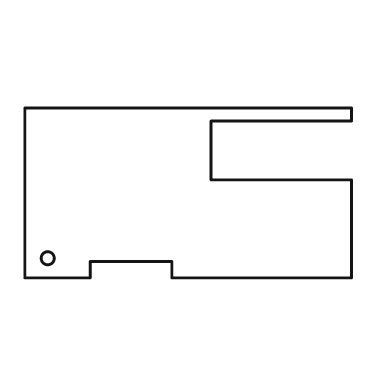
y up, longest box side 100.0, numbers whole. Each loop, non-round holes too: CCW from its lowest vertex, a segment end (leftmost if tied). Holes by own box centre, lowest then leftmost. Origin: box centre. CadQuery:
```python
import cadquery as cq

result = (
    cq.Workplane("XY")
    .moveTo(-50.0, -26.0)
    .lineTo(-30.0, -26.0)
    .lineTo(-30.0, -21.0)
    .lineTo(-5.0, -21.0)
    .lineTo(-5.0, -26.0)
    .lineTo(50.0, -26.0)
    .lineTo(50.0, 4.0)
    .lineTo(7.0, 4.0)
    .lineTo(7.0, 22.0)
    .lineTo(50.0, 22.0)
    .lineTo(50.0, 26.0)
    .lineTo(-50.0, 26.0)
    .close()
    .moveTo(-43.0, -20.0)
    .circle(2.0)
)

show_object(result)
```